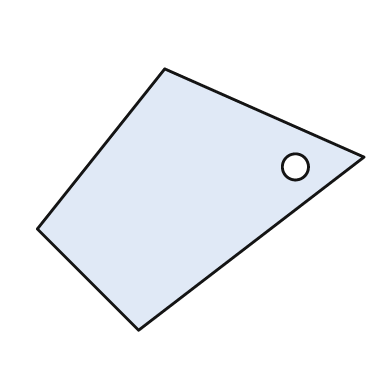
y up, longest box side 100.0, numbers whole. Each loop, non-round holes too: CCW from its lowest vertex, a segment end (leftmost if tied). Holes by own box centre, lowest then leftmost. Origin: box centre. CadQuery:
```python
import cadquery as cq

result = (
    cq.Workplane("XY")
    .moveTo(-19.0, -40.0)
    .lineTo(50.0, 13.0)
    .lineTo(-11.0, 40.0)
    .lineTo(-50.0, -9.0)
    .close()
    .moveTo(29.0, 10.0)
    .circle(4.0)
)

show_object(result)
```